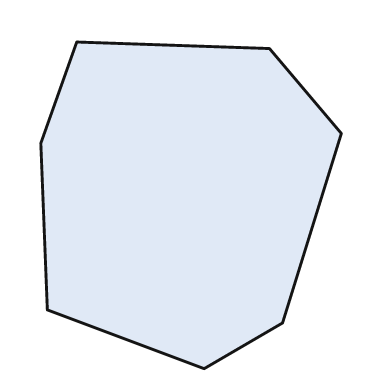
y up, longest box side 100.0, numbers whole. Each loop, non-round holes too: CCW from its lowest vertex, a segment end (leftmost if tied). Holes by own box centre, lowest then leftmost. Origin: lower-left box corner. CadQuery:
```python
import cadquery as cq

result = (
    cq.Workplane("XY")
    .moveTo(50.0, 0.0)
    .lineTo(74.0, 14.0)
    .lineTo(92.0, 72.0)
    .lineTo(70.0, 98.0)
    .lineTo(11.0, 100.0)
    .lineTo(0.0, 69.0)
    .lineTo(2.0, 18.0)
    .close()
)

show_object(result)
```